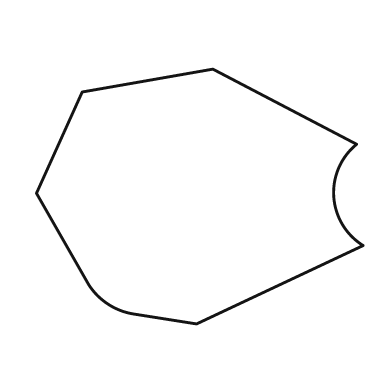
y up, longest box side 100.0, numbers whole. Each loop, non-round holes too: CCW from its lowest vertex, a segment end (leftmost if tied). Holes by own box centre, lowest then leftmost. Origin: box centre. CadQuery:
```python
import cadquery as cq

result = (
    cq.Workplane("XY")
    .moveTo(-1.0, -39.0)
    .lineTo(50.0, -15.0)
    .threePointArc((41.0, 0.0), (48.0, 16.0))
    .lineTo(4.0, 39.0)
    .lineTo(-36.0, 32.0)
    .lineTo(-50.0, 1.0)
    .lineTo(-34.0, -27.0)
    .threePointArc((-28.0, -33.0), (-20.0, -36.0))
    .close()
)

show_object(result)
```